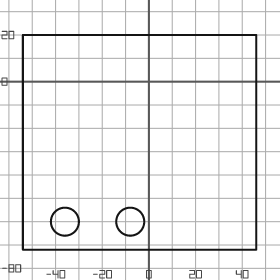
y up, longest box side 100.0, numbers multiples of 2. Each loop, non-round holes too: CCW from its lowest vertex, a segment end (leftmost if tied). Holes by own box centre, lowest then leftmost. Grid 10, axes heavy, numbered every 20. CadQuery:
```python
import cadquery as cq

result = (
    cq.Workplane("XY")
    .moveTo(-54.0, -72.0)
    .lineTo(46.0, -72.0)
    .lineTo(46.0, 20.0)
    .lineTo(-54.0, 20.0)
    .close()
    .moveTo(-36.0, -60.0)
    .circle(6.0)
    .moveTo(-8.0, -60.0)
    .circle(6.0)
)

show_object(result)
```